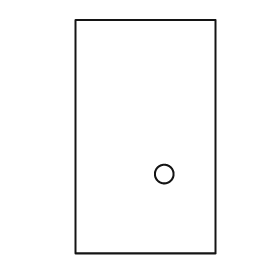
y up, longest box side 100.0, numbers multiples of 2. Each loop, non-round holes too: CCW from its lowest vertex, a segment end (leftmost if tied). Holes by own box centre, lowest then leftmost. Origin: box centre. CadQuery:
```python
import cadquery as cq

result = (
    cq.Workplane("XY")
    .moveTo(-30.0, -50.0)
    .lineTo(30.0, -50.0)
    .lineTo(30.0, 50.0)
    .lineTo(-30.0, 50.0)
    .close()
    .moveTo(8.0, -16.0)
    .circle(4.0)
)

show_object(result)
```